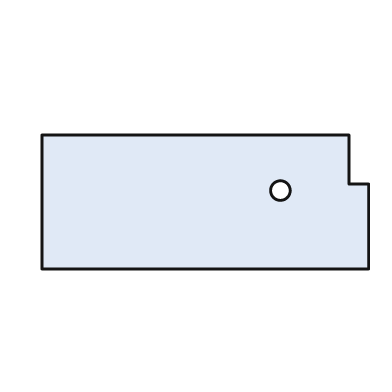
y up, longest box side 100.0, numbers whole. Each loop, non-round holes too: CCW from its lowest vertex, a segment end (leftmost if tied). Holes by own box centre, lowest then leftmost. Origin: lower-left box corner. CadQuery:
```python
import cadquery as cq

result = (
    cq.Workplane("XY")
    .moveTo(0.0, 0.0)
    .lineTo(100.0, 0.0)
    .lineTo(100.0, 26.0)
    .lineTo(94.0, 26.0)
    .lineTo(94.0, 41.0)
    .lineTo(0.0, 41.0)
    .close()
    .moveTo(73.0, 24.0)
    .circle(3.0)
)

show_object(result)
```